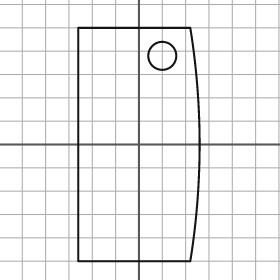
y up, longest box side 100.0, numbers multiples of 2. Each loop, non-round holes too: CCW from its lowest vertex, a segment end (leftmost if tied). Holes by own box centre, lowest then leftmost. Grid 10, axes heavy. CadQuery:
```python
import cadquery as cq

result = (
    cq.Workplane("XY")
    .moveTo(-26.0, -50.0)
    .lineTo(22.0, -50.0)
    .threePointArc((26.0, 0.0), (22.0, 50.0))
    .lineTo(-26.0, 50.0)
    .close()
    .moveTo(10.0, 38.0)
    .circle(6.0)
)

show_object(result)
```